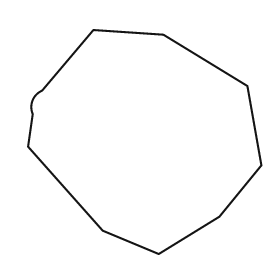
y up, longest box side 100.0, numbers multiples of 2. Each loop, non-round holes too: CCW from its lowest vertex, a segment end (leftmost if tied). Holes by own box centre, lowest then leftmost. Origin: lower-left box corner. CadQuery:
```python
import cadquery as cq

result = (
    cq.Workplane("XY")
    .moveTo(56.0, 0.0)
    .lineTo(82.0, 16.0)
    .lineTo(100.0, 38.0)
    .lineTo(94.0, 72.0)
    .lineTo(58.0, 94.0)
    .lineTo(28.0, 96.0)
    .lineTo(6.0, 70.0)
    .threePointArc((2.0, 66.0), (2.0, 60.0))
    .lineTo(0.0, 46.0)
    .lineTo(32.0, 10.0)
    .close()
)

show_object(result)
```